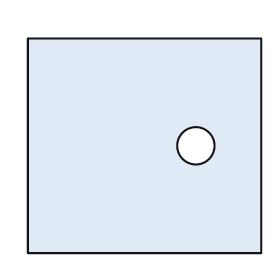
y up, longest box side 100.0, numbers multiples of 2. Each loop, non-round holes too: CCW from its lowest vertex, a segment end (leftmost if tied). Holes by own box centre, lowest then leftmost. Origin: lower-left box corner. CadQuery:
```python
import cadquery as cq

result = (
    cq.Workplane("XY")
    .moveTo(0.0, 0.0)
    .lineTo(100.0, 0.0)
    .lineTo(100.0, 92.0)
    .lineTo(0.0, 92.0)
    .close()
    .moveTo(72.0, 46.0)
    .circle(8.0)
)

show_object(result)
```